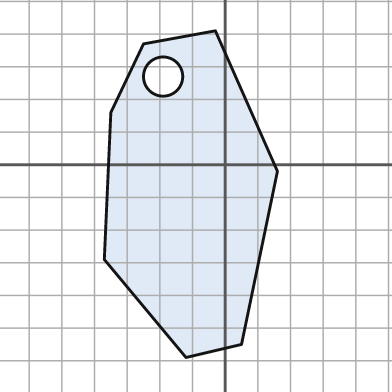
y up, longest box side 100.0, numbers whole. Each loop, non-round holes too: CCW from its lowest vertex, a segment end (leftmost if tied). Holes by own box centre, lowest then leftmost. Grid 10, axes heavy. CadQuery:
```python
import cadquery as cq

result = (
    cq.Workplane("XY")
    .moveTo(-12.0, -59.0)
    .lineTo(5.0, -55.0)
    .lineTo(16.0, -2.0)
    .lineTo(-3.0, 41.0)
    .lineTo(-25.0, 37.0)
    .lineTo(-35.0, 16.0)
    .lineTo(-37.0, -29.0)
    .close()
    .moveTo(-19.0, 27.0)
    .circle(6.0)
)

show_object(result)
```